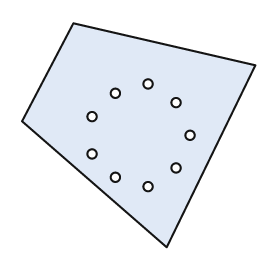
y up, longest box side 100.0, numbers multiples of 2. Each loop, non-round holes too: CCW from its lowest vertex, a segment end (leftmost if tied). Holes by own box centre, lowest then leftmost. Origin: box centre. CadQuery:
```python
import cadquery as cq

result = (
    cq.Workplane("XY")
    .moveTo(12.0, -48.0)
    .lineTo(50.0, 30.0)
    .lineTo(-28.0, 48.0)
    .lineTo(-50.0, 6.0)
    .close()
    .moveTo(4.0, -22.0)
    .circle(2.0)
    .moveTo(-10.0, -18.0)
    .circle(2.0)
    .moveTo(16.0, -14.0)
    .circle(2.0)
    .moveTo(-20.0, -8.0)
    .circle(2.0)
    .moveTo(22.0, 0.0)
    .circle(2.0)
    .moveTo(-20.0, 8.0)
    .circle(2.0)
    .moveTo(16.0, 14.0)
    .circle(2.0)
    .moveTo(-10.0, 18.0)
    .circle(2.0)
    .moveTo(4.0, 22.0)
    .circle(2.0)
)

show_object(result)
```